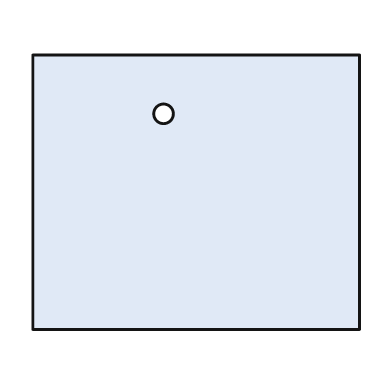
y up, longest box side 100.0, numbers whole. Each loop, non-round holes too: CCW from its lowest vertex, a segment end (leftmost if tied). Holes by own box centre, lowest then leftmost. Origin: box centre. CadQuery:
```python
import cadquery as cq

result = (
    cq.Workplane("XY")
    .moveTo(-50.0, -42.0)
    .lineTo(50.0, -42.0)
    .lineTo(50.0, 42.0)
    .lineTo(-50.0, 42.0)
    .close()
    .moveTo(-10.0, 24.0)
    .circle(3.0)
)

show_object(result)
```